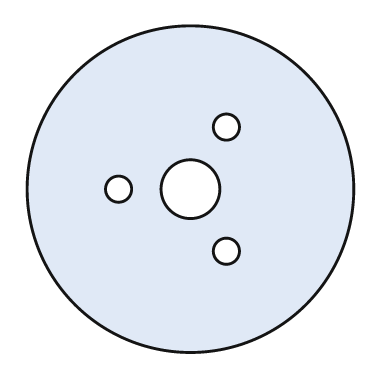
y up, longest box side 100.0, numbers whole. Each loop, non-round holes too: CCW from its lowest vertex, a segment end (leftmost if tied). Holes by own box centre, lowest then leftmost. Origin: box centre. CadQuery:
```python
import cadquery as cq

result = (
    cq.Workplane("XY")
    .moveTo(0.0, 0.0)
    .circle(50.0)
    .moveTo(11.0, -19.0)
    .circle(4.0)
    .moveTo(-22.0, 0.0)
    .circle(4.0)
    .moveTo(0.0, 0.0)
    .circle(9.0)
    .moveTo(11.0, 19.0)
    .circle(4.0)
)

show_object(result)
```